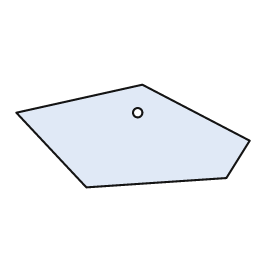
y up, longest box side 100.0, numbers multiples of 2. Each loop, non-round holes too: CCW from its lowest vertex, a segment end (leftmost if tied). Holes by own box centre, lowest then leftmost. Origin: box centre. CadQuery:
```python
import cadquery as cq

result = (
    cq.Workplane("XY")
    .moveTo(-20.0, -22.0)
    .lineTo(40.0, -18.0)
    .lineTo(50.0, -2.0)
    .lineTo(4.0, 22.0)
    .lineTo(-50.0, 10.0)
    .close()
    .moveTo(2.0, 10.0)
    .circle(2.0)
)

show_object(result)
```